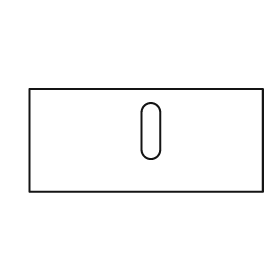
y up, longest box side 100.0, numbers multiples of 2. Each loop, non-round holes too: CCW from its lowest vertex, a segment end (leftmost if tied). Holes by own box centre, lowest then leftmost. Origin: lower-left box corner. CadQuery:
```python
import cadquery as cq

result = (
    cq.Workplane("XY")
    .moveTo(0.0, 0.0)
    .lineTo(100.0, 0.0)
    .lineTo(100.0, 44.0)
    .lineTo(0.0, 44.0)
    .close()
    .moveTo(48.0, 18.0)
    .threePointArc((52.0, 14.0), (56.0, 18.0))
    .lineTo(56.0, 34.0)
    .threePointArc((52.0, 38.0), (48.0, 34.0))
    .close()
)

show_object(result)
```